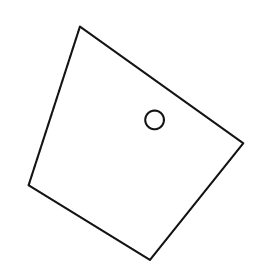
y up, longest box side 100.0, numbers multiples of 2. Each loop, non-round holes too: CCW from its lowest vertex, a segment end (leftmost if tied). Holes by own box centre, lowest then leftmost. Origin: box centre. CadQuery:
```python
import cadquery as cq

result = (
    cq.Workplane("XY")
    .moveTo(6.0, -50.0)
    .lineTo(46.0, 0.0)
    .lineTo(-24.0, 50.0)
    .lineTo(-46.0, -18.0)
    .close()
    .moveTo(8.0, 10.0)
    .circle(4.0)
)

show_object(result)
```